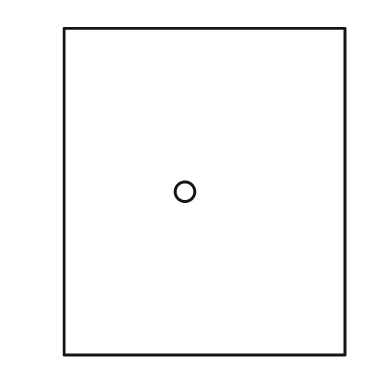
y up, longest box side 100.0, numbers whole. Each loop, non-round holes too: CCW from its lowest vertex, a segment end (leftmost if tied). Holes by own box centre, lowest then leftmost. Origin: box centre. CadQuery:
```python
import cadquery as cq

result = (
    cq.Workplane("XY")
    .moveTo(-43.0, -50.0)
    .lineTo(43.0, -50.0)
    .lineTo(43.0, 50.0)
    .lineTo(-43.0, 50.0)
    .close()
    .moveTo(-6.0, 0.0)
    .circle(3.0)
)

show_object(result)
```